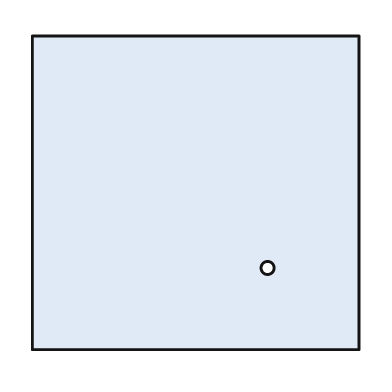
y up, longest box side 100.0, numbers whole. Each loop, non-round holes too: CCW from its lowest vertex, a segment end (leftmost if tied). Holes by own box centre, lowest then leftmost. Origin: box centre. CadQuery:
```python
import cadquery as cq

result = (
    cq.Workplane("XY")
    .moveTo(-50.0, -48.0)
    .lineTo(50.0, -48.0)
    .lineTo(50.0, 48.0)
    .lineTo(-50.0, 48.0)
    .close()
    .moveTo(22.0, -23.0)
    .circle(2.0)
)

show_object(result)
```